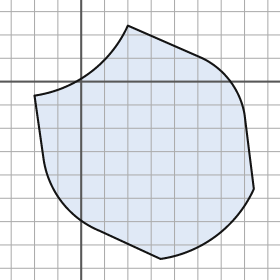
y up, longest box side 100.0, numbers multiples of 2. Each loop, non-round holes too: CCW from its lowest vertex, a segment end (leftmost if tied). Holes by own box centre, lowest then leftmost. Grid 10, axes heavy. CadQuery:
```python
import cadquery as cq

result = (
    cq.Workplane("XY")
    .moveTo(34.0, -76.0)
    .threePointArc((58.0, -66.0), (74.0, -46.0))
    .lineTo(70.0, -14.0)
    .threePointArc((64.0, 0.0), (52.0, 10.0))
    .lineTo(20.0, 24.0)
    .threePointArc((4.0, 4.0), (-20.0, -6.0))
    .lineTo(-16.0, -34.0)
    .threePointArc((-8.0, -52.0), (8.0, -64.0))
    .close()
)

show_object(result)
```